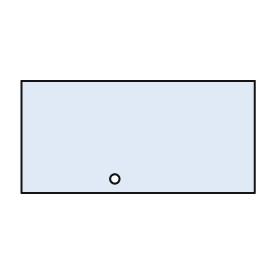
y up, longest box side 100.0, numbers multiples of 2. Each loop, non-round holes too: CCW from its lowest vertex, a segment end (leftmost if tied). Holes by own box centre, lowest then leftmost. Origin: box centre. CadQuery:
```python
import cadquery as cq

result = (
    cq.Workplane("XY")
    .moveTo(-50.0, -24.0)
    .lineTo(50.0, -24.0)
    .lineTo(50.0, 24.0)
    .lineTo(-50.0, 24.0)
    .close()
    .moveTo(-10.0, -18.0)
    .circle(2.0)
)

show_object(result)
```